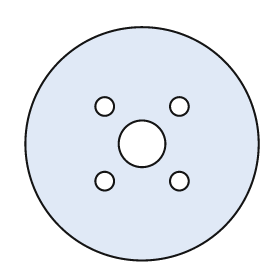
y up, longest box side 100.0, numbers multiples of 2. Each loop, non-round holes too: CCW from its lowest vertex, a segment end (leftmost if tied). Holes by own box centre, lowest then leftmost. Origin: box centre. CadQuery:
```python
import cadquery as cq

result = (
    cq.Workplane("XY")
    .moveTo(0.0, 0.0)
    .circle(50.0)
    .moveTo(-16.0, -16.0)
    .circle(4.0)
    .moveTo(16.0, -16.0)
    .circle(4.0)
    .moveTo(0.0, 0.0)
    .circle(10.0)
    .moveTo(-16.0, 16.0)
    .circle(4.0)
    .moveTo(16.0, 16.0)
    .circle(4.0)
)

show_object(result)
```